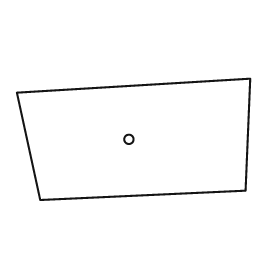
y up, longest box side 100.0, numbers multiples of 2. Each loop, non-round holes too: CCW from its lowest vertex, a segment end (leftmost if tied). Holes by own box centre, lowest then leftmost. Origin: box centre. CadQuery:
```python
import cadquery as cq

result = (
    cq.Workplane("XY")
    .moveTo(-40.0, -26.0)
    .lineTo(48.0, -22.0)
    .lineTo(50.0, 26.0)
    .lineTo(-50.0, 20.0)
    .close()
    .moveTo(-2.0, 0.0)
    .circle(2.0)
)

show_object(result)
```